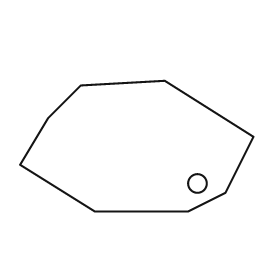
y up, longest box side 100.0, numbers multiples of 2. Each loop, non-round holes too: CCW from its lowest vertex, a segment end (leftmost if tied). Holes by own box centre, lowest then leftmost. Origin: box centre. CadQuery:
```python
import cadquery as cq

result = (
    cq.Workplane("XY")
    .moveTo(-18.0, -28.0)
    .lineTo(22.0, -28.0)
    .lineTo(38.0, -20.0)
    .lineTo(50.0, 4.0)
    .lineTo(12.0, 28.0)
    .lineTo(-24.0, 26.0)
    .lineTo(-38.0, 12.0)
    .lineTo(-50.0, -8.0)
    .close()
    .moveTo(26.0, -16.0)
    .circle(4.0)
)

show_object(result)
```